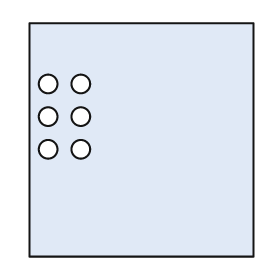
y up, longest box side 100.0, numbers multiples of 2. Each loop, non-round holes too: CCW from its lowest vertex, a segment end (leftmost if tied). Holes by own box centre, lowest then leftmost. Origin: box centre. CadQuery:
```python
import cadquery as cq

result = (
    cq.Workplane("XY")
    .moveTo(-48.0, -50.0)
    .lineTo(48.0, -50.0)
    .lineTo(48.0, 50.0)
    .lineTo(-48.0, 50.0)
    .close()
    .moveTo(-40.0, -4.0)
    .circle(4.0)
    .moveTo(-26.0, -4.0)
    .circle(4.0)
    .moveTo(-40.0, 10.0)
    .circle(4.0)
    .moveTo(-26.0, 10.0)
    .circle(4.0)
    .moveTo(-40.0, 24.0)
    .circle(4.0)
    .moveTo(-26.0, 24.0)
    .circle(4.0)
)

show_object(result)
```